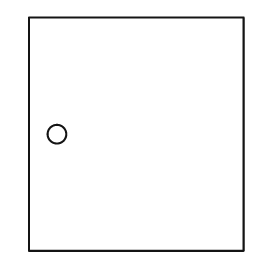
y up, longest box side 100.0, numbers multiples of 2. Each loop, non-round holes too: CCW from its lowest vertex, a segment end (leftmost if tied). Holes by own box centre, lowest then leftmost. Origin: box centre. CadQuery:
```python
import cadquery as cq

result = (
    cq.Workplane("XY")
    .moveTo(-46.0, -50.0)
    .lineTo(46.0, -50.0)
    .lineTo(46.0, 50.0)
    .lineTo(-46.0, 50.0)
    .close()
    .moveTo(-34.0, 0.0)
    .circle(4.0)
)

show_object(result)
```